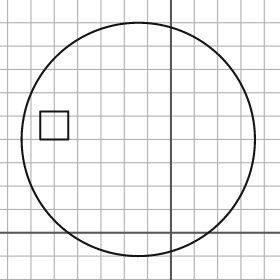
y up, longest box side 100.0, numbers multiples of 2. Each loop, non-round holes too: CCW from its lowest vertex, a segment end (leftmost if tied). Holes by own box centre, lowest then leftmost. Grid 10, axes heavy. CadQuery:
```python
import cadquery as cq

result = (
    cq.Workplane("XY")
    .moveTo(-14.0, 40.0)
    .circle(50.0)
    .moveTo(-56.0, 40.0)
    .lineTo(-44.0, 40.0)
    .lineTo(-44.0, 52.0)
    .lineTo(-56.0, 52.0)
    .close()
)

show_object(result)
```